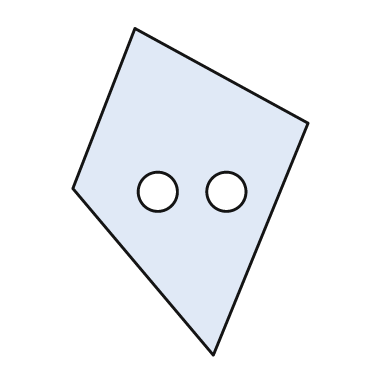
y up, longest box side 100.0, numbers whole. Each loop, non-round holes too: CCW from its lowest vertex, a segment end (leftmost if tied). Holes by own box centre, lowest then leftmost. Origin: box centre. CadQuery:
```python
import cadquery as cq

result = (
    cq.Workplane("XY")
    .moveTo(7.0, -50.0)
    .lineTo(36.0, 21.0)
    .lineTo(-17.0, 50.0)
    .lineTo(-36.0, 1.0)
    .close()
    .moveTo(-10.0, 0.0)
    .circle(6.0)
    .moveTo(11.0, 0.0)
    .circle(6.0)
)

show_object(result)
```